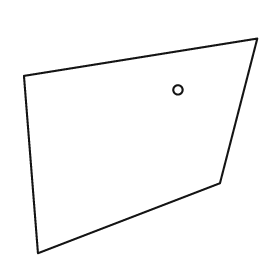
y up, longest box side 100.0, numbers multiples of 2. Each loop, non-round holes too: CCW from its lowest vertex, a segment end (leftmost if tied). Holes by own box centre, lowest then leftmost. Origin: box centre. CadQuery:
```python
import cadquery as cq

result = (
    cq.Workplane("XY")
    .moveTo(-44.0, -46.0)
    .lineTo(34.0, -16.0)
    .lineTo(50.0, 46.0)
    .lineTo(-50.0, 30.0)
    .close()
    .moveTo(16.0, 24.0)
    .circle(2.0)
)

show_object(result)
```